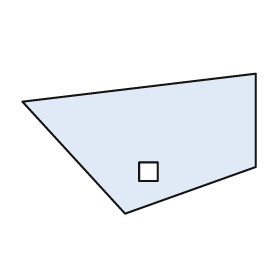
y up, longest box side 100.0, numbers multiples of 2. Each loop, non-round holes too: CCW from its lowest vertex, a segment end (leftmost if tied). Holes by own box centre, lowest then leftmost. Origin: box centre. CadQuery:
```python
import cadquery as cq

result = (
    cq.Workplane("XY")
    .moveTo(-6.0, -30.0)
    .lineTo(50.0, -10.0)
    .lineTo(50.0, 30.0)
    .lineTo(-50.0, 18.0)
    .close()
    .moveTo(0.0, -16.0)
    .lineTo(8.0, -16.0)
    .lineTo(8.0, -8.0)
    .lineTo(0.0, -8.0)
    .close()
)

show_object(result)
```